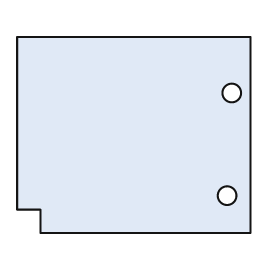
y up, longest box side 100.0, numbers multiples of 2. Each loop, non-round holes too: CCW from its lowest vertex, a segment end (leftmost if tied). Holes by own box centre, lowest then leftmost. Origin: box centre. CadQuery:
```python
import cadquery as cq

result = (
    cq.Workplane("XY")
    .moveTo(-40.0, -42.0)
    .lineTo(50.0, -42.0)
    .lineTo(50.0, 42.0)
    .lineTo(-50.0, 42.0)
    .lineTo(-50.0, -32.0)
    .lineTo(-40.0, -32.0)
    .close()
    .moveTo(40.0, -26.0)
    .circle(4.0)
    .moveTo(42.0, 18.0)
    .circle(4.0)
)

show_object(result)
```